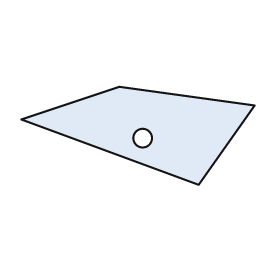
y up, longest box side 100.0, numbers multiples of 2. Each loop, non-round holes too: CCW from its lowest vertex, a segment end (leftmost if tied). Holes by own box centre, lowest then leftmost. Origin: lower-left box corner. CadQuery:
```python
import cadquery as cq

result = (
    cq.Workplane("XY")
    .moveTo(76.0, 0.0)
    .lineTo(100.0, 34.0)
    .lineTo(42.0, 42.0)
    .lineTo(0.0, 28.0)
    .close()
    .moveTo(52.0, 20.0)
    .circle(4.0)
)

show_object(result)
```